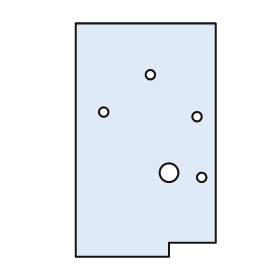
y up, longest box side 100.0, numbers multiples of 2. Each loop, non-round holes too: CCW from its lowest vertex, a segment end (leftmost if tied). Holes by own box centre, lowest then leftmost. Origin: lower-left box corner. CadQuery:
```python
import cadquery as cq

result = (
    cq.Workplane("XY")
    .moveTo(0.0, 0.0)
    .lineTo(40.0, 0.0)
    .lineTo(40.0, 6.0)
    .lineTo(60.0, 6.0)
    .lineTo(60.0, 100.0)
    .lineTo(0.0, 100.0)
    .close()
    .moveTo(54.0, 34.0)
    .circle(2.0)
    .moveTo(40.0, 36.0)
    .circle(4.0)
    .moveTo(52.0, 60.0)
    .circle(2.0)
    .moveTo(12.0, 62.0)
    .circle(2.0)
    .moveTo(32.0, 78.0)
    .circle(2.0)
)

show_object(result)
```